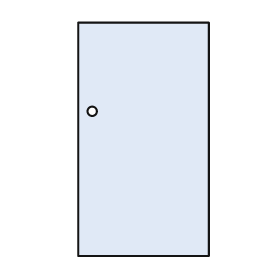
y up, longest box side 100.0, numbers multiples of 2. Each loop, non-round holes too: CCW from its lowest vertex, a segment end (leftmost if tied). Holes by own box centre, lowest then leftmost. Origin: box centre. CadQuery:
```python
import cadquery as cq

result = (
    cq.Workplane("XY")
    .moveTo(-28.0, -50.0)
    .lineTo(28.0, -50.0)
    .lineTo(28.0, 50.0)
    .lineTo(-28.0, 50.0)
    .close()
    .moveTo(-22.0, 12.0)
    .circle(2.0)
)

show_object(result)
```